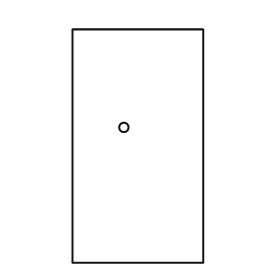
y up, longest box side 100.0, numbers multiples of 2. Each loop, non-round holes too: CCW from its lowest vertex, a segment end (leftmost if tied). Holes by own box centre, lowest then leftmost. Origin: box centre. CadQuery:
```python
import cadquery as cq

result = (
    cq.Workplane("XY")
    .moveTo(-28.0, -50.0)
    .lineTo(28.0, -50.0)
    .lineTo(28.0, 50.0)
    .lineTo(-28.0, 50.0)
    .close()
    .moveTo(-6.0, 8.0)
    .circle(2.0)
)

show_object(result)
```